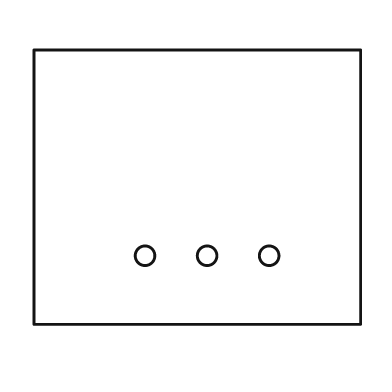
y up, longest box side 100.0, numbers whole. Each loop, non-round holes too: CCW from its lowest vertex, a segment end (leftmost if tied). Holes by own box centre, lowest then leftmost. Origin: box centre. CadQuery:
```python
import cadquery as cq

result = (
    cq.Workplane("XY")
    .moveTo(-50.0, -42.0)
    .lineTo(50.0, -42.0)
    .lineTo(50.0, 42.0)
    .lineTo(-50.0, 42.0)
    .close()
    .moveTo(-16.0, -21.0)
    .circle(3.0)
    .moveTo(3.0, -21.0)
    .circle(3.0)
    .moveTo(22.0, -21.0)
    .circle(3.0)
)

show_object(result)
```